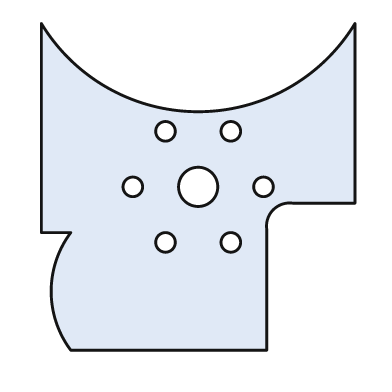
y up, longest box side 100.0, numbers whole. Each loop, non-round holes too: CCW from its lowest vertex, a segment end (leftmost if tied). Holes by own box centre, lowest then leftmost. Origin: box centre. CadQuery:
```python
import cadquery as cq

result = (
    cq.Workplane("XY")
    .moveTo(-39.0, -50.0)
    .lineTo(21.0, -50.0)
    .lineTo(21.0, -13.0)
    .threePointArc((23.0, -7.0), (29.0, -5.0))
    .lineTo(48.0, -5.0)
    .lineTo(48.0, 50.0)
    .threePointArc((0.0, 23.0), (-48.0, 50.0))
    .lineTo(-48.0, -14.0)
    .lineTo(-39.0, -14.0)
    .threePointArc((-45.0, -32.0), (-39.0, -50.0))
    .close()
    .moveTo(-10.0, -17.0)
    .circle(3.0)
    .moveTo(10.0, -17.0)
    .circle(3.0)
    .moveTo(-20.0, 0.0)
    .circle(3.0)
    .moveTo(0.0, 0.0)
    .circle(6.0)
    .moveTo(20.0, 0.0)
    .circle(3.0)
    .moveTo(-10.0, 17.0)
    .circle(3.0)
    .moveTo(10.0, 17.0)
    .circle(3.0)
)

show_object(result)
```